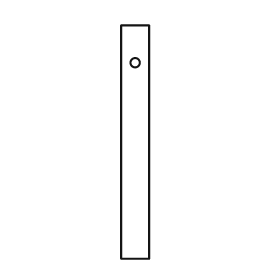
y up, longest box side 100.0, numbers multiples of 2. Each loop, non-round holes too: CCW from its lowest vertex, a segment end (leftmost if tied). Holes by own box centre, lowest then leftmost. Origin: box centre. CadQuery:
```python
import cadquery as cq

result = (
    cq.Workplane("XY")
    .moveTo(-6.0, -50.0)
    .lineTo(6.0, -50.0)
    .lineTo(6.0, 50.0)
    .lineTo(-6.0, 50.0)
    .close()
    .moveTo(0.0, 34.0)
    .circle(2.0)
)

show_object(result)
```